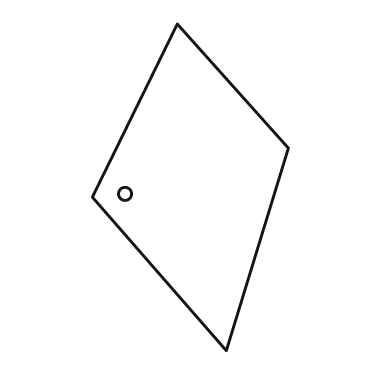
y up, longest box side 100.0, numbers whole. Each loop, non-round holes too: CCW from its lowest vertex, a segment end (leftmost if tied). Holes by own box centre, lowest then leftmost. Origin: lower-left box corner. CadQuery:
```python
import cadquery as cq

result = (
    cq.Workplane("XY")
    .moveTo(41.0, 0.0)
    .lineTo(60.0, 62.0)
    .lineTo(26.0, 100.0)
    .lineTo(0.0, 47.0)
    .close()
    .moveTo(10.0, 48.0)
    .circle(2.0)
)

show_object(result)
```